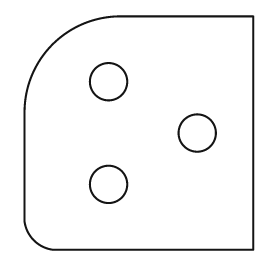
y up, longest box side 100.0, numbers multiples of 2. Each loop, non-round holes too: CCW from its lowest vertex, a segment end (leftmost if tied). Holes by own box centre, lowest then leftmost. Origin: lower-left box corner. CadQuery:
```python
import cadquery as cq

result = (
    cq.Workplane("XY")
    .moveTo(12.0, 0.0)
    .lineTo(98.0, 0.0)
    .lineTo(98.0, 100.0)
    .lineTo(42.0, 100.0)
    .threePointArc((12.0, 88.0), (0.0, 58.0))
    .lineTo(0.0, 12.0)
    .threePointArc((4.0, 4.0), (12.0, 0.0))
    .close()
    .moveTo(36.0, 28.0)
    .circle(8.0)
    .moveTo(74.0, 50.0)
    .circle(8.0)
    .moveTo(36.0, 72.0)
    .circle(8.0)
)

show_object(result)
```